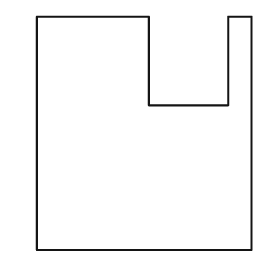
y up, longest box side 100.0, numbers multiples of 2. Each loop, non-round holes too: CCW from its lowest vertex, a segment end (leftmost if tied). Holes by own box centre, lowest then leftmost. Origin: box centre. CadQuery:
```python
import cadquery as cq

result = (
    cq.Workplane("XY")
    .moveTo(-46.0, -50.0)
    .lineTo(46.0, -50.0)
    .lineTo(46.0, 50.0)
    .lineTo(36.0, 50.0)
    .lineTo(36.0, 12.0)
    .lineTo(2.0, 12.0)
    .lineTo(2.0, 50.0)
    .lineTo(-46.0, 50.0)
    .close()
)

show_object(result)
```